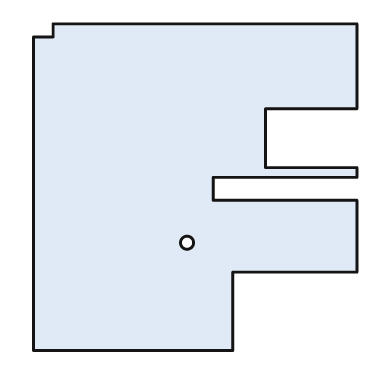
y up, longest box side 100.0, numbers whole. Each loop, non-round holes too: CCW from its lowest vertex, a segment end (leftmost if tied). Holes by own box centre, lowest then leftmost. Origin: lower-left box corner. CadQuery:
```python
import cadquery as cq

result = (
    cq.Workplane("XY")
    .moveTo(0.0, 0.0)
    .lineTo(61.0, 0.0)
    .lineTo(61.0, 24.0)
    .lineTo(99.0, 24.0)
    .lineTo(99.0, 46.0)
    .lineTo(55.0, 46.0)
    .lineTo(55.0, 53.0)
    .lineTo(99.0, 53.0)
    .lineTo(99.0, 56.0)
    .lineTo(71.0, 56.0)
    .lineTo(71.0, 74.0)
    .lineTo(99.0, 74.0)
    .lineTo(99.0, 100.0)
    .lineTo(6.0, 100.0)
    .lineTo(6.0, 96.0)
    .lineTo(0.0, 96.0)
    .close()
    .moveTo(47.0, 33.0)
    .circle(2.0)
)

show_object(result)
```